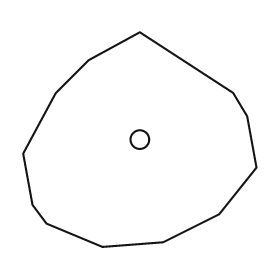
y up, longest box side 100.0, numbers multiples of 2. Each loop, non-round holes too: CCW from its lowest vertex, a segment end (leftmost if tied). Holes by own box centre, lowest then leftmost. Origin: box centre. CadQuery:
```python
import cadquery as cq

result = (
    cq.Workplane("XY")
    .moveTo(-16.0, -46.0)
    .lineTo(10.0, -44.0)
    .lineTo(34.0, -32.0)
    .lineTo(50.0, -12.0)
    .lineTo(46.0, 10.0)
    .lineTo(40.0, 20.0)
    .lineTo(0.0, 46.0)
    .lineTo(-22.0, 34.0)
    .lineTo(-36.0, 20.0)
    .lineTo(-50.0, -6.0)
    .lineTo(-46.0, -28.0)
    .lineTo(-40.0, -36.0)
    .close()
    .moveTo(0.0, 0.0)
    .circle(4.0)
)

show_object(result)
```